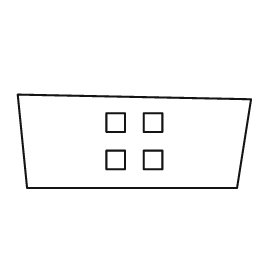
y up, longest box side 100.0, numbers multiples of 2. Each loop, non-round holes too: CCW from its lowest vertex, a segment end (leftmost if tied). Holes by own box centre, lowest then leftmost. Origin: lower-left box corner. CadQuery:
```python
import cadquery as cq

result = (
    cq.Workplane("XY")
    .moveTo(4.0, 0.0)
    .lineTo(94.0, 0.0)
    .lineTo(100.0, 38.0)
    .lineTo(0.0, 40.0)
    .close()
    .moveTo(38.0, 8.0)
    .lineTo(46.0, 8.0)
    .lineTo(46.0, 16.0)
    .lineTo(38.0, 16.0)
    .close()
    .moveTo(54.0, 8.0)
    .lineTo(62.0, 8.0)
    .lineTo(62.0, 16.0)
    .lineTo(54.0, 16.0)
    .close()
    .moveTo(38.0, 24.0)
    .lineTo(46.0, 24.0)
    .lineTo(46.0, 32.0)
    .lineTo(38.0, 32.0)
    .close()
    .moveTo(54.0, 24.0)
    .lineTo(62.0, 24.0)
    .lineTo(62.0, 32.0)
    .lineTo(54.0, 32.0)
    .close()
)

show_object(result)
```